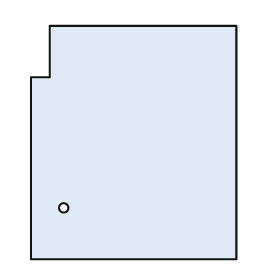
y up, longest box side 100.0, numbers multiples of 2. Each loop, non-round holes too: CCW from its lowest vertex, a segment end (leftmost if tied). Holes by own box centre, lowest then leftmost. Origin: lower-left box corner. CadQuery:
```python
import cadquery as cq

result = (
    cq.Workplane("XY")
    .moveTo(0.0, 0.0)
    .lineTo(88.0, 0.0)
    .lineTo(88.0, 100.0)
    .lineTo(8.0, 100.0)
    .lineTo(8.0, 78.0)
    .lineTo(0.0, 78.0)
    .close()
    .moveTo(14.0, 22.0)
    .circle(2.0)
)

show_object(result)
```